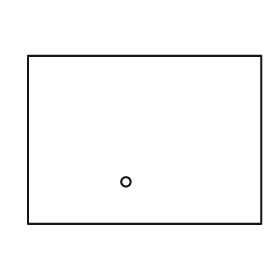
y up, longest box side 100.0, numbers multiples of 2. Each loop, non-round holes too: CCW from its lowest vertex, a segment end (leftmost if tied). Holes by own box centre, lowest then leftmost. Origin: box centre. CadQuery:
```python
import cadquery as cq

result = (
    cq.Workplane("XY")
    .moveTo(-50.0, -36.0)
    .lineTo(50.0, -36.0)
    .lineTo(50.0, 36.0)
    .lineTo(-50.0, 36.0)
    .close()
    .moveTo(-8.0, -18.0)
    .circle(2.0)
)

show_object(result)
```